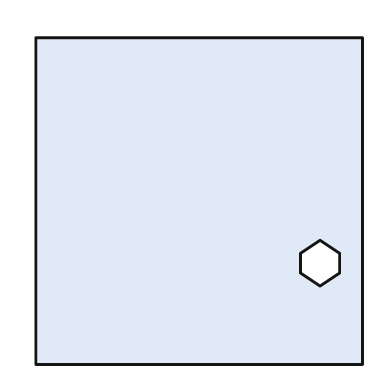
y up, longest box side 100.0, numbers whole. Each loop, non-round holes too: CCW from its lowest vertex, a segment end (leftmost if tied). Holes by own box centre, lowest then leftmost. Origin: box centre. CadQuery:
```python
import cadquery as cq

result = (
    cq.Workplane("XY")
    .moveTo(-50.0, -50.0)
    .lineTo(50.0, -50.0)
    .lineTo(50.0, 50.0)
    .lineTo(-50.0, 50.0)
    .close()
    .moveTo(37.0, -26.0)
    .lineTo(43.0, -22.0)
    .lineTo(43.0, -16.0)
    .lineTo(37.0, -12.0)
    .lineTo(31.0, -16.0)
    .lineTo(31.0, -22.0)
    .close()
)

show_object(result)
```